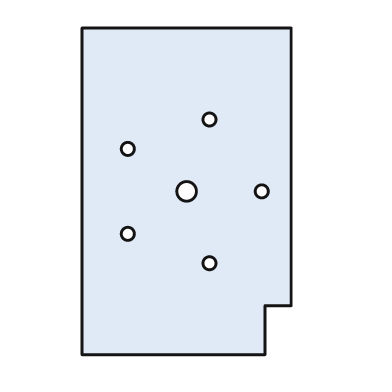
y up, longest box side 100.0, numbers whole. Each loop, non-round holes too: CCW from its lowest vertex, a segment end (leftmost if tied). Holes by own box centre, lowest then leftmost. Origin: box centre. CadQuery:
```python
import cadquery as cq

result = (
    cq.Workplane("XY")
    .moveTo(-32.0, -50.0)
    .lineTo(24.0, -50.0)
    .lineTo(24.0, -35.0)
    .lineTo(32.0, -35.0)
    .lineTo(32.0, 50.0)
    .lineTo(-32.0, 50.0)
    .close()
    .moveTo(7.0, -22.0)
    .circle(2.0)
    .moveTo(-18.0, -13.0)
    .circle(2.0)
    .moveTo(0.0, 0.0)
    .circle(3.0)
    .moveTo(23.0, 0.0)
    .circle(2.0)
    .moveTo(-18.0, 13.0)
    .circle(2.0)
    .moveTo(7.0, 22.0)
    .circle(2.0)
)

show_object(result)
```